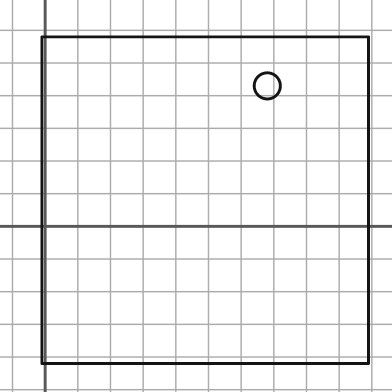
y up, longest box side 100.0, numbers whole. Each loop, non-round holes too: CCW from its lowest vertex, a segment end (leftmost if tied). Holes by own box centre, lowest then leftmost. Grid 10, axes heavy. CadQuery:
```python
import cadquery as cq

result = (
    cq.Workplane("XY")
    .moveTo(-1.0, -42.0)
    .lineTo(99.0, -42.0)
    .lineTo(99.0, 58.0)
    .lineTo(-1.0, 58.0)
    .close()
    .moveTo(68.0, 43.0)
    .circle(4.0)
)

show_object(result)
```